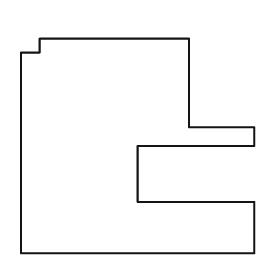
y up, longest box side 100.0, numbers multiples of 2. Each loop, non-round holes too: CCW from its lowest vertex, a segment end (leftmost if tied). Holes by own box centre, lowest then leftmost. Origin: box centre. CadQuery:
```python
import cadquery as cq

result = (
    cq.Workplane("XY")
    .moveTo(-50.0, -46.0)
    .lineTo(50.0, -46.0)
    .lineTo(50.0, -24.0)
    .lineTo(0.0, -24.0)
    .lineTo(0.0, 0.0)
    .lineTo(50.0, 0.0)
    .lineTo(50.0, 8.0)
    .lineTo(22.0, 8.0)
    .lineTo(22.0, 46.0)
    .lineTo(-42.0, 46.0)
    .lineTo(-42.0, 40.0)
    .lineTo(-50.0, 40.0)
    .close()
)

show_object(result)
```